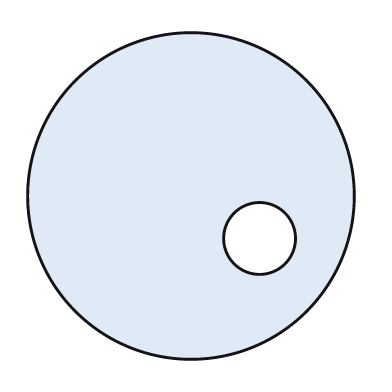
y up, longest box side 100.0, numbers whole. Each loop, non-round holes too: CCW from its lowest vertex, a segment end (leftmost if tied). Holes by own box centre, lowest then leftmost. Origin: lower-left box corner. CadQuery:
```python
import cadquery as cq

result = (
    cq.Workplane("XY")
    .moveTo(50.0, 50.0)
    .circle(50.0)
    .moveTo(71.0, 37.0)
    .circle(11.0)
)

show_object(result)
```